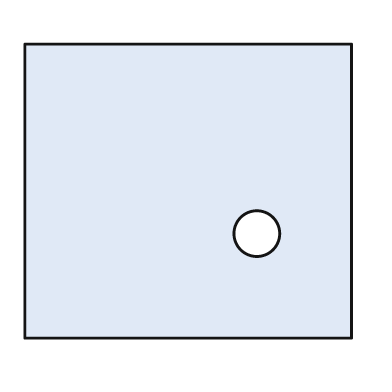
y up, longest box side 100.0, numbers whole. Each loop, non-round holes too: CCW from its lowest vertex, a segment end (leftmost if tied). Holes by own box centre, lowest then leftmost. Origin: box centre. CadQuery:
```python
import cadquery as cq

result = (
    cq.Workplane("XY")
    .moveTo(-50.0, -45.0)
    .lineTo(50.0, -45.0)
    .lineTo(50.0, 45.0)
    .lineTo(-50.0, 45.0)
    .close()
    .moveTo(21.0, -13.0)
    .circle(7.0)
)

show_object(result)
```